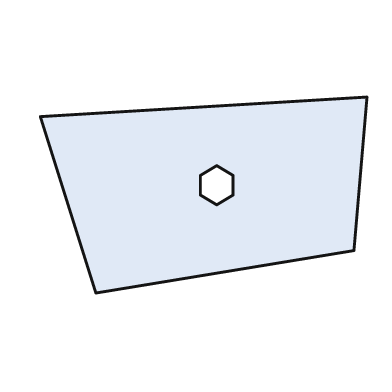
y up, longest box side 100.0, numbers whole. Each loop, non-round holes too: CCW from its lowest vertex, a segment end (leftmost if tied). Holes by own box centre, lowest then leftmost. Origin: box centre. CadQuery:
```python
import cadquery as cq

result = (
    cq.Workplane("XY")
    .moveTo(-33.0, -30.0)
    .lineTo(46.0, -17.0)
    .lineTo(50.0, 30.0)
    .lineTo(-50.0, 24.0)
    .close()
    .moveTo(4.0, -3.0)
    .lineTo(9.0, 0.0)
    .lineTo(9.0, 6.0)
    .lineTo(4.0, 9.0)
    .lineTo(-1.0, 6.0)
    .lineTo(-1.0, 0.0)
    .close()
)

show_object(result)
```